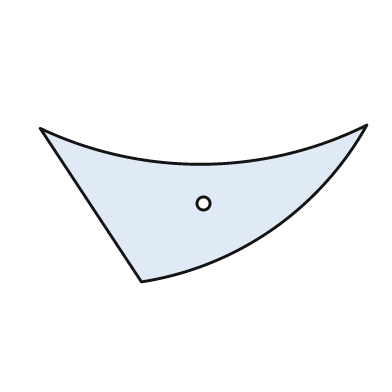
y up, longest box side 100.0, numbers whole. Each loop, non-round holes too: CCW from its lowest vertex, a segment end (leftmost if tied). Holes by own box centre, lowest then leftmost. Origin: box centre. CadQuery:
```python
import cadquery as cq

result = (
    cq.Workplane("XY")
    .moveTo(-19.0, -24.0)
    .threePointArc((21.0, -8.0), (50.0, 24.0))
    .threePointArc((0.0, 12.0), (-50.0, 23.0))
    .close()
    .moveTo(0.0, 0.0)
    .circle(2.0)
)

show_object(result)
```